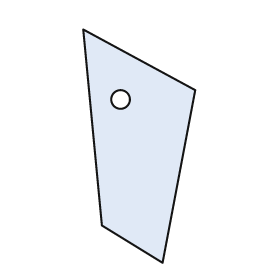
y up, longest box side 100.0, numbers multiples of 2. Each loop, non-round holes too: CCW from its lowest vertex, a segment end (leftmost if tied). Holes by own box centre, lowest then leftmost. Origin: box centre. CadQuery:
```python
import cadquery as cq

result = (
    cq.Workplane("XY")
    .moveTo(10.0, -50.0)
    .lineTo(24.0, 24.0)
    .lineTo(-24.0, 50.0)
    .lineTo(-16.0, -34.0)
    .close()
    .moveTo(-8.0, 20.0)
    .circle(4.0)
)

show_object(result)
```